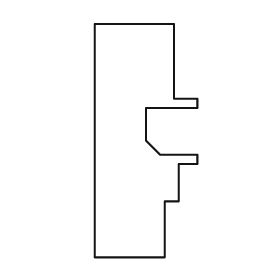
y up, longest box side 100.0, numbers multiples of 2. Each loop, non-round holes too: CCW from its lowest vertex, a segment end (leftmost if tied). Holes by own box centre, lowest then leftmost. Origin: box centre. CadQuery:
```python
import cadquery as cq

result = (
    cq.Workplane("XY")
    .moveTo(-22.0, -50.0)
    .lineTo(8.0, -50.0)
    .lineTo(8.0, -26.0)
    .lineTo(14.0, -26.0)
    .lineTo(14.0, -10.0)
    .lineTo(22.0, -10.0)
    .lineTo(22.0, -6.0)
    .lineTo(6.0, -6.0)
    .lineTo(0.0, 0.0)
    .lineTo(0.0, 14.0)
    .lineTo(22.0, 14.0)
    .lineTo(22.0, 18.0)
    .lineTo(12.0, 18.0)
    .lineTo(12.0, 50.0)
    .lineTo(-22.0, 50.0)
    .close()
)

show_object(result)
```